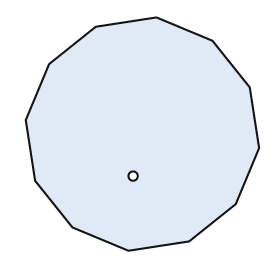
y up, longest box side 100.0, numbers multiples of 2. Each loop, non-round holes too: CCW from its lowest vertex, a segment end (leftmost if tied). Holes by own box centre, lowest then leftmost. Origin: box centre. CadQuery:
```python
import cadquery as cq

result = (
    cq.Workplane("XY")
    .moveTo(-6.0, -50.0)
    .lineTo(20.0, -46.0)
    .lineTo(40.0, -30.0)
    .lineTo(50.0, -6.0)
    .lineTo(46.0, 20.0)
    .lineTo(30.0, 40.0)
    .lineTo(6.0, 50.0)
    .lineTo(-20.0, 46.0)
    .lineTo(-40.0, 30.0)
    .lineTo(-50.0, 6.0)
    .lineTo(-46.0, -20.0)
    .lineTo(-30.0, -40.0)
    .close()
    .moveTo(-4.0, -18.0)
    .circle(2.0)
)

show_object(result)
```